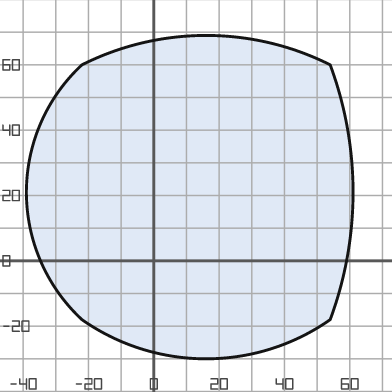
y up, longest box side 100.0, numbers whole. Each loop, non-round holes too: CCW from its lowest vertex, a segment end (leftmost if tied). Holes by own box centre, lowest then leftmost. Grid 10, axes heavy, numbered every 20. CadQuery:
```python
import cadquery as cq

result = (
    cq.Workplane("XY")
    .moveTo(-22.0, -18.0)
    .threePointArc((16.0, -30.0), (54.0, -18.0))
    .threePointArc((61.0, 21.0), (54.0, 60.0))
    .threePointArc((16.0, 69.0), (-22.0, 60.0))
    .threePointArc((-39.0, 21.0), (-22.0, -18.0))
    .close()
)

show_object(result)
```